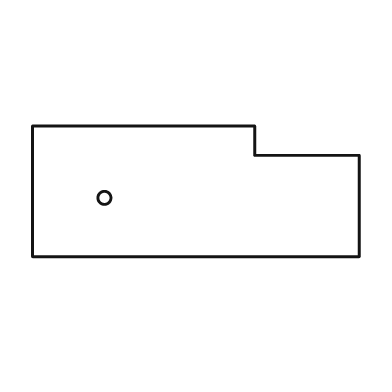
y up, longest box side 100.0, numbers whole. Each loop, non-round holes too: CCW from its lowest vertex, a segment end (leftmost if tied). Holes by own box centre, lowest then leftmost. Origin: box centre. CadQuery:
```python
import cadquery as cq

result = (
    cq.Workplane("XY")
    .moveTo(-50.0, -20.0)
    .lineTo(50.0, -20.0)
    .lineTo(50.0, 11.0)
    .lineTo(18.0, 11.0)
    .lineTo(18.0, 20.0)
    .lineTo(-50.0, 20.0)
    .close()
    .moveTo(-28.0, -2.0)
    .circle(2.0)
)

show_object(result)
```